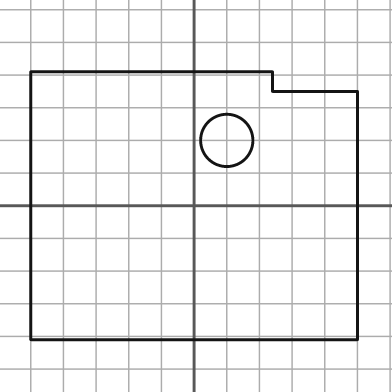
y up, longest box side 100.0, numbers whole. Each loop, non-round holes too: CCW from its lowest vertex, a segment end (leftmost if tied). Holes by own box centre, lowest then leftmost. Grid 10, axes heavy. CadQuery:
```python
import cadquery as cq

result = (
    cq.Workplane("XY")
    .moveTo(-50.0, -41.0)
    .lineTo(50.0, -41.0)
    .lineTo(50.0, 35.0)
    .lineTo(24.0, 35.0)
    .lineTo(24.0, 41.0)
    .lineTo(-50.0, 41.0)
    .close()
    .moveTo(10.0, 20.0)
    .circle(8.0)
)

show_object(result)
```